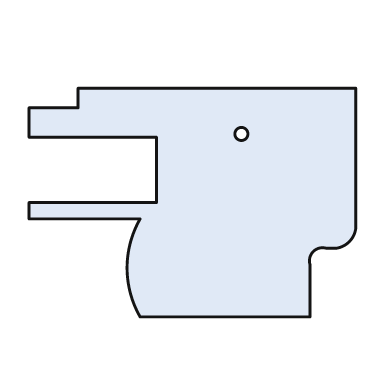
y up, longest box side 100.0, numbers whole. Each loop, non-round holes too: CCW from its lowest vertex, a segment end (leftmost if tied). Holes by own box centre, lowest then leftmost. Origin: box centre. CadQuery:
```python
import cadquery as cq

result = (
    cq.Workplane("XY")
    .moveTo(-16.0, -35.0)
    .lineTo(36.0, -35.0)
    .lineTo(36.0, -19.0)
    .threePointArc((37.0, -15.0), (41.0, -14.0))
    .lineTo(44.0, -14.0)
    .threePointArc((48.0, -12.0), (50.0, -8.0))
    .lineTo(50.0, 35.0)
    .lineTo(-35.0, 35.0)
    .lineTo(-35.0, 29.0)
    .lineTo(-50.0, 29.0)
    .lineTo(-50.0, 20.0)
    .lineTo(-11.0, 20.0)
    .lineTo(-11.0, 0.0)
    .lineTo(-50.0, 0.0)
    .lineTo(-50.0, -5.0)
    .lineTo(-16.0, -5.0)
    .threePointArc((-20.0, -20.0), (-16.0, -35.0))
    .close()
    .moveTo(15.0, 21.0)
    .circle(2.0)
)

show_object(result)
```